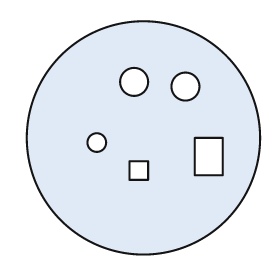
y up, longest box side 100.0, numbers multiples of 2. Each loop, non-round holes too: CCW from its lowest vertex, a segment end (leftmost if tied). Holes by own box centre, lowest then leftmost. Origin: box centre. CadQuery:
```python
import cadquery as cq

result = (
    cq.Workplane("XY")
    .moveTo(0.0, 0.0)
    .circle(50.0)
    .moveTo(-6.0, -18.0)
    .lineTo(2.0, -18.0)
    .lineTo(2.0, -10.0)
    .lineTo(-6.0, -10.0)
    .close()
    .moveTo(22.0, -16.0)
    .lineTo(34.0, -16.0)
    .lineTo(34.0, 0.0)
    .lineTo(22.0, 0.0)
    .close()
    .moveTo(-20.0, -2.0)
    .circle(4.0)
    .moveTo(18.0, 22.0)
    .circle(6.0)
    .moveTo(-4.0, 24.0)
    .circle(6.0)
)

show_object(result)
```